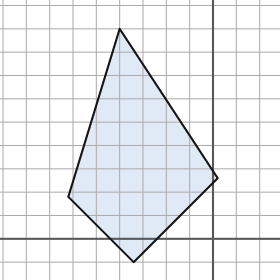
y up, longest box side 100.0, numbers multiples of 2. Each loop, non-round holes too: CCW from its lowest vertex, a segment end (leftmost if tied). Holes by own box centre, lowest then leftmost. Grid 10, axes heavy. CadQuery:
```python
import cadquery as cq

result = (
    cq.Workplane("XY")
    .moveTo(-34.0, -10.0)
    .lineTo(2.0, 26.0)
    .lineTo(-40.0, 90.0)
    .lineTo(-62.0, 18.0)
    .close()
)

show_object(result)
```